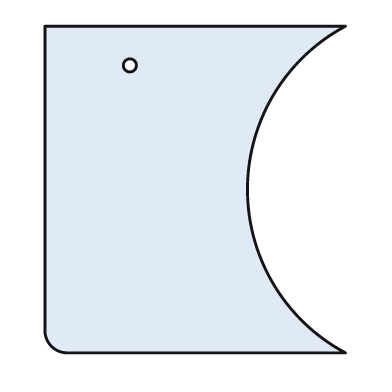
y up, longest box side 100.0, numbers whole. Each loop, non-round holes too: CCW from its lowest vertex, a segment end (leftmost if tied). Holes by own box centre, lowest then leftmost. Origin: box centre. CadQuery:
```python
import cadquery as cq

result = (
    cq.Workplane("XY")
    .moveTo(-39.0, -50.0)
    .lineTo(46.0, -50.0)
    .threePointArc((16.0, 0.0), (46.0, 50.0))
    .lineTo(-46.0, 50.0)
    .lineTo(-46.0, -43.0)
    .threePointArc((-44.0, -48.0), (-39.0, -50.0))
    .close()
    .moveTo(-20.0, 38.0)
    .circle(2.0)
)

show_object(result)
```